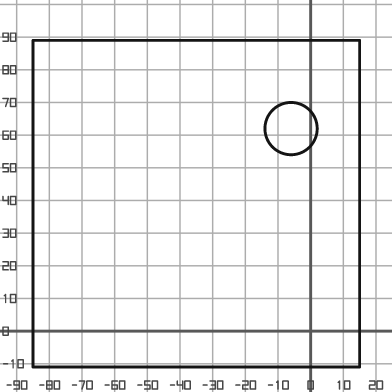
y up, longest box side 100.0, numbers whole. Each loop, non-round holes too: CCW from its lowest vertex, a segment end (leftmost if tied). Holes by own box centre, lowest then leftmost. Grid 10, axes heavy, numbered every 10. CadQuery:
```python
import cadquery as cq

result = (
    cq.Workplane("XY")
    .moveTo(-85.0, -11.0)
    .lineTo(15.0, -11.0)
    .lineTo(15.0, 89.0)
    .lineTo(-85.0, 89.0)
    .close()
    .moveTo(-6.0, 62.0)
    .circle(8.0)
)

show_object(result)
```